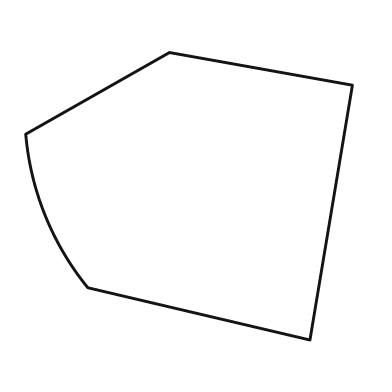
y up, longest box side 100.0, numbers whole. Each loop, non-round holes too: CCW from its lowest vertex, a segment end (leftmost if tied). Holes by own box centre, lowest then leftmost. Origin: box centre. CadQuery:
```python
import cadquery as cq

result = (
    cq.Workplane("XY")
    .moveTo(37.0, -44.0)
    .lineTo(50.0, 34.0)
    .lineTo(-6.0, 44.0)
    .lineTo(-50.0, 19.0)
    .threePointArc((-44.0, -6.0), (-31.0, -28.0))
    .close()
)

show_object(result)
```